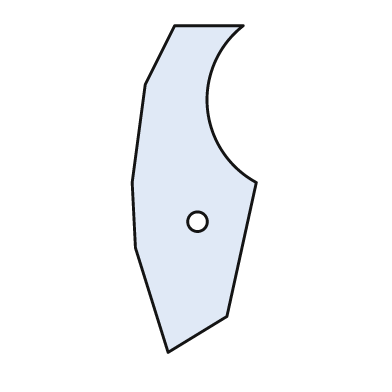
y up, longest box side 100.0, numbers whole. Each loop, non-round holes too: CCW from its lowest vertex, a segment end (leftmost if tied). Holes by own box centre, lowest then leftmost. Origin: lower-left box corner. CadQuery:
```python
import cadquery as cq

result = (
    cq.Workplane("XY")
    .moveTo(11.0, 0.0)
    .lineTo(29.0, 11.0)
    .lineTo(38.0, 52.0)
    .threePointArc((23.0, 75.0), (34.0, 100.0))
    .lineTo(13.0, 100.0)
    .lineTo(4.0, 82.0)
    .lineTo(0.0, 52.0)
    .lineTo(1.0, 32.0)
    .close()
    .moveTo(20.0, 40.0)
    .circle(3.0)
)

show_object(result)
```